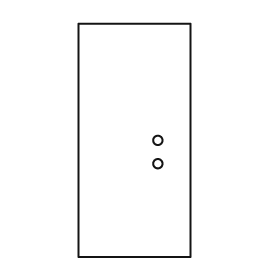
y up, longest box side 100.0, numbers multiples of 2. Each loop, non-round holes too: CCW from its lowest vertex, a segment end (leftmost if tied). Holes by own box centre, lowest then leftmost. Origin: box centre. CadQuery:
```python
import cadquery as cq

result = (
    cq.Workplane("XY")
    .moveTo(-24.0, -50.0)
    .lineTo(24.0, -50.0)
    .lineTo(24.0, 50.0)
    .lineTo(-24.0, 50.0)
    .close()
    .moveTo(10.0, -10.0)
    .circle(2.0)
    .moveTo(10.0, 0.0)
    .circle(2.0)
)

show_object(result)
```